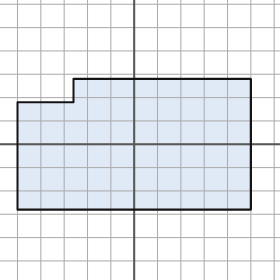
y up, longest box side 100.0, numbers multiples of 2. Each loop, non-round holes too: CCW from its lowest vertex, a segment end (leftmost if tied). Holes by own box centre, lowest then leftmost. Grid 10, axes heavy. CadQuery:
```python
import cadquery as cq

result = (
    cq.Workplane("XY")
    .moveTo(-50.0, -28.0)
    .lineTo(50.0, -28.0)
    .lineTo(50.0, 28.0)
    .lineTo(-26.0, 28.0)
    .lineTo(-26.0, 18.0)
    .lineTo(-50.0, 18.0)
    .close()
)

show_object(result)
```